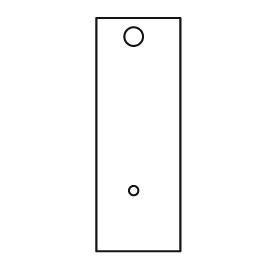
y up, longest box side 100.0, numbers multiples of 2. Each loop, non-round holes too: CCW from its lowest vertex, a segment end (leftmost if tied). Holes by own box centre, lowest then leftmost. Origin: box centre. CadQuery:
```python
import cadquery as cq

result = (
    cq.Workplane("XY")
    .moveTo(-18.0, -50.0)
    .lineTo(18.0, -50.0)
    .lineTo(18.0, 50.0)
    .lineTo(-18.0, 50.0)
    .close()
    .moveTo(-2.0, -24.0)
    .circle(2.0)
    .moveTo(-2.0, 42.0)
    .circle(4.0)
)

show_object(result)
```